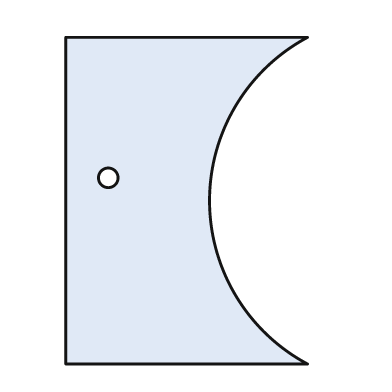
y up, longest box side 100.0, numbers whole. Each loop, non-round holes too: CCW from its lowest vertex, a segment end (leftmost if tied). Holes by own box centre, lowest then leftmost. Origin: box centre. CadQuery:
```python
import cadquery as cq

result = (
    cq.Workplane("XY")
    .moveTo(-37.0, -50.0)
    .lineTo(37.0, -50.0)
    .threePointArc((7.0, 0.0), (37.0, 50.0))
    .lineTo(-37.0, 50.0)
    .close()
    .moveTo(-24.0, 7.0)
    .circle(3.0)
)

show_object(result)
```